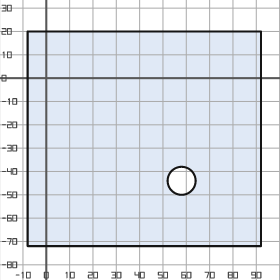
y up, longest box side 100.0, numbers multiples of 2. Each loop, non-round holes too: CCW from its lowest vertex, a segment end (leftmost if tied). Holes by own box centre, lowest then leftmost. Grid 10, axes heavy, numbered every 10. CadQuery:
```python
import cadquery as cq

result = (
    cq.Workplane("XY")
    .moveTo(-8.0, -72.0)
    .lineTo(92.0, -72.0)
    .lineTo(92.0, 20.0)
    .lineTo(-8.0, 20.0)
    .close()
    .moveTo(58.0, -44.0)
    .circle(6.0)
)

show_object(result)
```